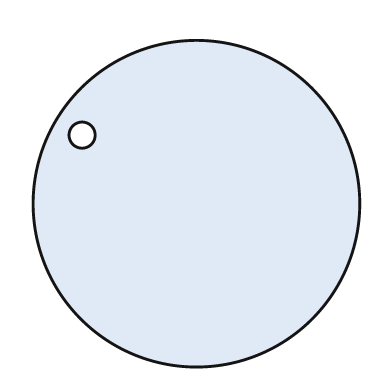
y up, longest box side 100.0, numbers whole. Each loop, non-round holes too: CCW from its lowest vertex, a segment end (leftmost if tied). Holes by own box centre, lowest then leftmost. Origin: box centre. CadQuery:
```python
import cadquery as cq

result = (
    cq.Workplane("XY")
    .moveTo(0.0, 0.0)
    .circle(50.0)
    .moveTo(-35.0, 21.0)
    .circle(4.0)
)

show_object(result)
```